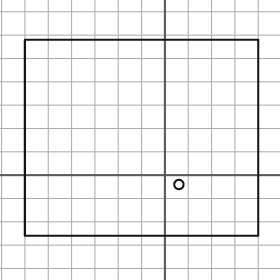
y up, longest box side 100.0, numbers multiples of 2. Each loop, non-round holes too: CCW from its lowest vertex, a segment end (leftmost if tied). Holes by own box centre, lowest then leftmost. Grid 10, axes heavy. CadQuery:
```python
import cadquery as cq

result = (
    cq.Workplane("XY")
    .moveTo(-60.0, -26.0)
    .lineTo(40.0, -26.0)
    .lineTo(40.0, 58.0)
    .lineTo(-60.0, 58.0)
    .close()
    .moveTo(6.0, -4.0)
    .circle(2.0)
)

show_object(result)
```